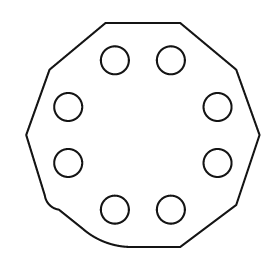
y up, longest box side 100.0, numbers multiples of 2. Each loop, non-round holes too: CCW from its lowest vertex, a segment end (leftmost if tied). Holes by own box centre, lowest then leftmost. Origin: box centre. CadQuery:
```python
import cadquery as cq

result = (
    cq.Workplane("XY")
    .moveTo(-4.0, -48.0)
    .lineTo(16.0, -48.0)
    .lineTo(40.0, -30.0)
    .lineTo(50.0, 0.0)
    .lineTo(40.0, 28.0)
    .lineTo(16.0, 48.0)
    .lineTo(-16.0, 48.0)
    .lineTo(-40.0, 28.0)
    .lineTo(-50.0, 0.0)
    .lineTo(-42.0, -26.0)
    .threePointArc((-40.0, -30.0), (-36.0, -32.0))
    .lineTo(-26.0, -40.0)
    .threePointArc((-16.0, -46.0), (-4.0, -48.0))
    .close()
    .moveTo(-12.0, -32.0)
    .circle(6.0)
    .moveTo(12.0, -32.0)
    .circle(6.0)
    .moveTo(-32.0, -12.0)
    .circle(6.0)
    .moveTo(32.0, -12.0)
    .circle(6.0)
    .moveTo(-32.0, 12.0)
    .circle(6.0)
    .moveTo(32.0, 12.0)
    .circle(6.0)
    .moveTo(-12.0, 32.0)
    .circle(6.0)
    .moveTo(12.0, 32.0)
    .circle(6.0)
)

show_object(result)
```